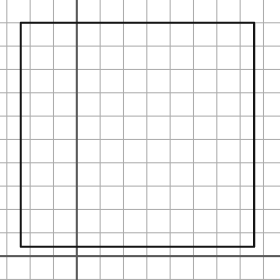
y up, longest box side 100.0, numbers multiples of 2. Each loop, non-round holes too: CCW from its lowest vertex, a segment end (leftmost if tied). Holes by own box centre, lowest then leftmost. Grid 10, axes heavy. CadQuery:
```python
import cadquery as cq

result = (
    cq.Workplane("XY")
    .moveTo(-24.0, 4.0)
    .lineTo(76.0, 4.0)
    .lineTo(76.0, 100.0)
    .lineTo(-24.0, 100.0)
    .close()
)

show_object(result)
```